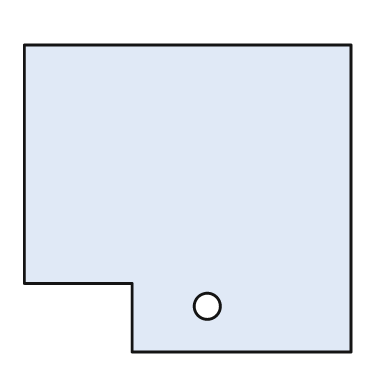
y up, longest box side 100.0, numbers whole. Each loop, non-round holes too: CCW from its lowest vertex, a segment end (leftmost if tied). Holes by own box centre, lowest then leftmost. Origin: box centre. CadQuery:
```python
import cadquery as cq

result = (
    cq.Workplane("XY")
    .moveTo(-17.0, -47.0)
    .lineTo(50.0, -47.0)
    .lineTo(50.0, 47.0)
    .lineTo(-50.0, 47.0)
    .lineTo(-50.0, -26.0)
    .lineTo(-17.0, -26.0)
    .close()
    .moveTo(6.0, -33.0)
    .circle(4.0)
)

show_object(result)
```